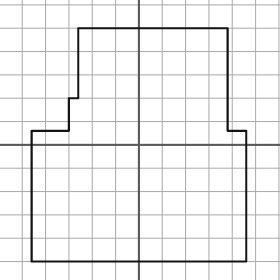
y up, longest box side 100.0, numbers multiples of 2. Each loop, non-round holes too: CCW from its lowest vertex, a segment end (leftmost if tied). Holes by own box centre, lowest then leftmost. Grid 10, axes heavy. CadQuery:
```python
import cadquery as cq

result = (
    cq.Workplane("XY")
    .moveTo(-46.0, -50.0)
    .lineTo(46.0, -50.0)
    .lineTo(46.0, 6.0)
    .lineTo(38.0, 6.0)
    .lineTo(38.0, 50.0)
    .lineTo(-26.0, 50.0)
    .lineTo(-26.0, 20.0)
    .lineTo(-30.0, 20.0)
    .lineTo(-30.0, 6.0)
    .lineTo(-46.0, 6.0)
    .close()
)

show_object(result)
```